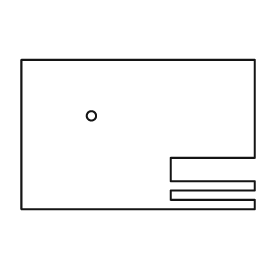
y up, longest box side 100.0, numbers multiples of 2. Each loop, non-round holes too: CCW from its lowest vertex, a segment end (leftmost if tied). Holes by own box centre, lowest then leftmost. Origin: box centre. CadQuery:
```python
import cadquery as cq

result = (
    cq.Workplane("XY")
    .moveTo(-50.0, -32.0)
    .lineTo(50.0, -32.0)
    .lineTo(50.0, -28.0)
    .lineTo(14.0, -28.0)
    .lineTo(14.0, -24.0)
    .lineTo(50.0, -24.0)
    .lineTo(50.0, -20.0)
    .lineTo(14.0, -20.0)
    .lineTo(14.0, -10.0)
    .lineTo(50.0, -10.0)
    .lineTo(50.0, 32.0)
    .lineTo(-50.0, 32.0)
    .close()
    .moveTo(-20.0, 8.0)
    .circle(2.0)
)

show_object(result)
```